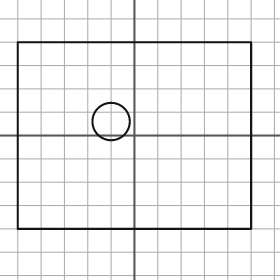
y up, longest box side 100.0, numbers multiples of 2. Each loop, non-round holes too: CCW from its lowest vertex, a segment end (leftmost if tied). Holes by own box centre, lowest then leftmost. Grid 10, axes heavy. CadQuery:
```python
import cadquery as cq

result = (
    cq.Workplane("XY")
    .moveTo(-50.0, -40.0)
    .lineTo(50.0, -40.0)
    .lineTo(50.0, 40.0)
    .lineTo(-50.0, 40.0)
    .close()
    .moveTo(-10.0, 6.0)
    .circle(8.0)
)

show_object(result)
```